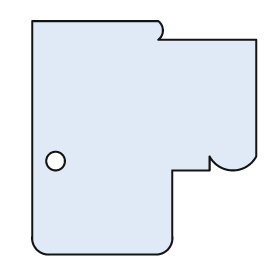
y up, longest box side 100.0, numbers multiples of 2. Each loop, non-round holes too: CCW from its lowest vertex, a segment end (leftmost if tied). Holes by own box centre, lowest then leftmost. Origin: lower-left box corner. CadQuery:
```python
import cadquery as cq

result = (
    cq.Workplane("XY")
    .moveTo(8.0, 0.0)
    .lineTo(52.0, 0.0)
    .threePointArc((58.0, 2.0), (60.0, 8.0))
    .lineTo(60.0, 36.0)
    .lineTo(76.0, 36.0)
    .lineTo(76.0, 42.0)
    .threePointArc((86.0, 36.0), (96.0, 42.0))
    .lineTo(96.0, 92.0)
    .lineTo(54.0, 92.0)
    .threePointArc((56.0, 96.0), (54.0, 100.0))
    .lineTo(0.0, 100.0)
    .lineTo(0.0, 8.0)
    .threePointArc((2.0, 2.0), (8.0, 0.0))
    .close()
    .moveTo(10.0, 40.0)
    .circle(4.0)
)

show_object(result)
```